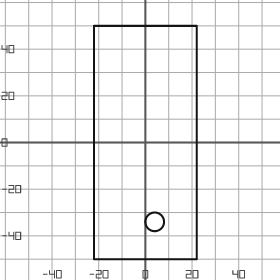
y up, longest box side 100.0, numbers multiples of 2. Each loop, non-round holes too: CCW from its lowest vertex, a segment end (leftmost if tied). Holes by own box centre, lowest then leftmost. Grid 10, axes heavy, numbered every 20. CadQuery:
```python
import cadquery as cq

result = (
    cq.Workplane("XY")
    .moveTo(-22.0, -50.0)
    .lineTo(22.0, -50.0)
    .lineTo(22.0, 50.0)
    .lineTo(-22.0, 50.0)
    .close()
    .moveTo(4.0, -34.0)
    .circle(4.0)
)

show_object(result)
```